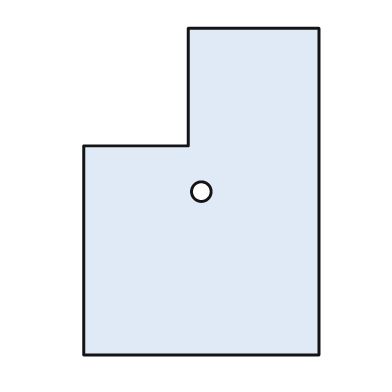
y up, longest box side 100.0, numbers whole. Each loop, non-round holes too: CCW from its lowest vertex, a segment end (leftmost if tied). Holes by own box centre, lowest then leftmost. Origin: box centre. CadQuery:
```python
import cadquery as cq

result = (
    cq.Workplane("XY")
    .moveTo(-36.0, -50.0)
    .lineTo(36.0, -50.0)
    .lineTo(36.0, 50.0)
    .lineTo(-4.0, 50.0)
    .lineTo(-4.0, 14.0)
    .lineTo(-36.0, 14.0)
    .close()
    .moveTo(0.0, 0.0)
    .circle(3.0)
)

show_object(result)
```